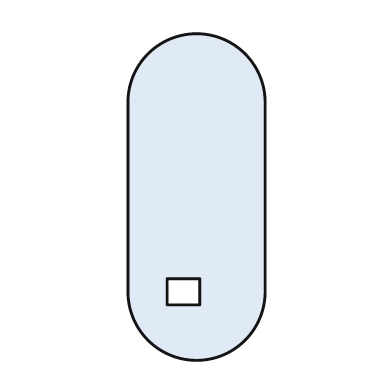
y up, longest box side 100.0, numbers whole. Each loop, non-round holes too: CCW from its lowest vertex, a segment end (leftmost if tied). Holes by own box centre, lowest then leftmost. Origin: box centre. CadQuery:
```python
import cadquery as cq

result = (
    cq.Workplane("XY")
    .moveTo(-21.0, -29.0)
    .threePointArc((0.0, -50.0), (21.0, -29.0))
    .lineTo(21.0, 29.0)
    .threePointArc((0.0, 50.0), (-21.0, 29.0))
    .close()
    .moveTo(-9.0, -33.0)
    .lineTo(1.0, -33.0)
    .lineTo(1.0, -25.0)
    .lineTo(-9.0, -25.0)
    .close()
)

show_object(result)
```